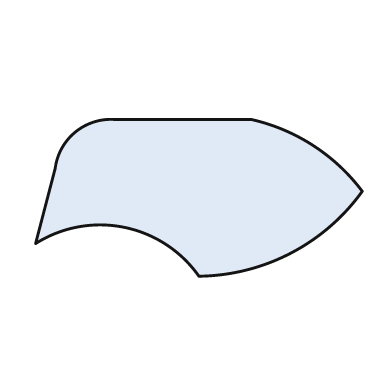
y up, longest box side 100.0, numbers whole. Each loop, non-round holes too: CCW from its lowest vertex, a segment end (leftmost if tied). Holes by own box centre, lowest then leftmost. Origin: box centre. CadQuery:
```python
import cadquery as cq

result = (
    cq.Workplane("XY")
    .moveTo(0.0, -24.0)
    .threePointArc((28.0, -17.0), (50.0, 2.0))
    .threePointArc((35.0, 16.0), (16.0, 24.0))
    .lineTo(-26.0, 24.0)
    .threePointArc((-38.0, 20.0), (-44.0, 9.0))
    .lineTo(-50.0, -14.0)
    .threePointArc((-23.0, -9.0), (0.0, -24.0))
    .close()
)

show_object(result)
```